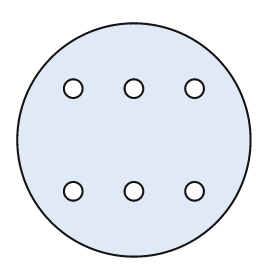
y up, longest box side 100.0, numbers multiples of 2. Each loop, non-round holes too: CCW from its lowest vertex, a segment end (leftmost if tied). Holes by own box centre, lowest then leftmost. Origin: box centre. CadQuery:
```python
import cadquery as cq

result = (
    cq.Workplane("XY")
    .moveTo(0.0, 0.0)
    .circle(50.0)
    .moveTo(-26.0, -22.0)
    .circle(4.0)
    .moveTo(0.0, -22.0)
    .circle(4.0)
    .moveTo(26.0, -22.0)
    .circle(4.0)
    .moveTo(-26.0, 22.0)
    .circle(4.0)
    .moveTo(0.0, 22.0)
    .circle(4.0)
    .moveTo(26.0, 22.0)
    .circle(4.0)
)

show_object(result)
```